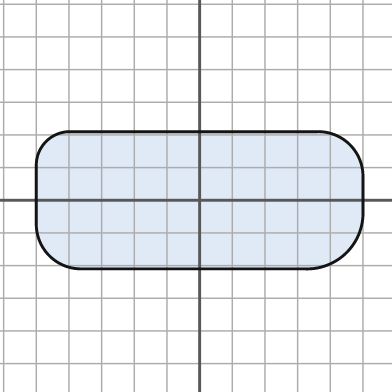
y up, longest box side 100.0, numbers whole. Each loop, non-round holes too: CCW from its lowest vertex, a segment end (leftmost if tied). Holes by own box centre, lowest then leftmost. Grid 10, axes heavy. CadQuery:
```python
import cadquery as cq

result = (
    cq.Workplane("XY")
    .moveTo(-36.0, -21.0)
    .lineTo(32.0, -21.0)
    .threePointArc((45.0, -16.0), (50.0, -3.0))
    .lineTo(50.0, 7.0)
    .threePointArc((46.0, 17.0), (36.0, 21.0))
    .lineTo(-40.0, 21.0)
    .threePointArc((-47.0, 18.0), (-50.0, 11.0))
    .lineTo(-50.0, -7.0)
    .threePointArc((-46.0, -17.0), (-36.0, -21.0))
    .close()
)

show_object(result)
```